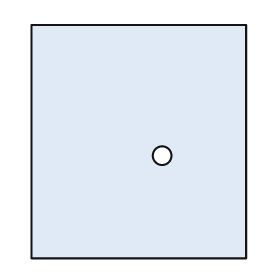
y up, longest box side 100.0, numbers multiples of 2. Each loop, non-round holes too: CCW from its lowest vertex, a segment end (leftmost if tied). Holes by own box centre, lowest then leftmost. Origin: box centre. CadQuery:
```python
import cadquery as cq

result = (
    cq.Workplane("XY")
    .moveTo(-46.0, -50.0)
    .lineTo(46.0, -50.0)
    .lineTo(46.0, 50.0)
    .lineTo(-46.0, 50.0)
    .close()
    .moveTo(10.0, -6.0)
    .circle(4.0)
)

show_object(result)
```